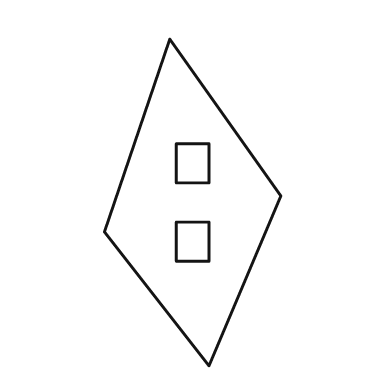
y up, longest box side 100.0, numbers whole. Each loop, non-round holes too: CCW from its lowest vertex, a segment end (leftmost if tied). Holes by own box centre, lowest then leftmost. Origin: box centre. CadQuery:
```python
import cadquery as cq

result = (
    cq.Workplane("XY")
    .moveTo(5.0, -50.0)
    .lineTo(27.0, 2.0)
    .lineTo(-7.0, 50.0)
    .lineTo(-27.0, -9.0)
    .close()
    .moveTo(-5.0, -18.0)
    .lineTo(5.0, -18.0)
    .lineTo(5.0, -6.0)
    .lineTo(-5.0, -6.0)
    .close()
    .moveTo(-5.0, 6.0)
    .lineTo(5.0, 6.0)
    .lineTo(5.0, 18.0)
    .lineTo(-5.0, 18.0)
    .close()
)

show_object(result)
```